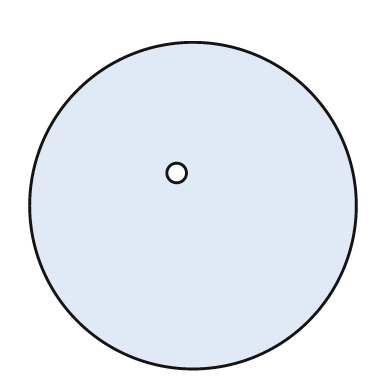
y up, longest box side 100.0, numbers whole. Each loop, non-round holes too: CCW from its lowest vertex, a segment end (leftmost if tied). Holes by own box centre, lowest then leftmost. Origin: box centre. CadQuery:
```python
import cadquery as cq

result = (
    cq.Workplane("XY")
    .moveTo(0.0, 0.0)
    .circle(50.0)
    .moveTo(-5.0, 10.0)
    .circle(3.0)
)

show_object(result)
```